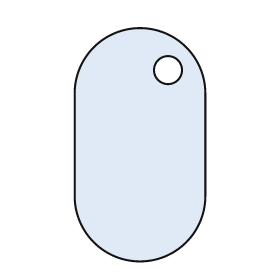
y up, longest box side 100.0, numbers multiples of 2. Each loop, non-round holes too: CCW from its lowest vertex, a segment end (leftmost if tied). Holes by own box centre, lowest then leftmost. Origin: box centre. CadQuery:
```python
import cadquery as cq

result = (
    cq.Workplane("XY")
    .moveTo(-28.0, -22.0)
    .threePointArc((0.0, -50.0), (28.0, -22.0))
    .lineTo(28.0, 22.0)
    .threePointArc((0.0, 50.0), (-28.0, 22.0))
    .close()
    .moveTo(12.0, 32.0)
    .circle(6.0)
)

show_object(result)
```